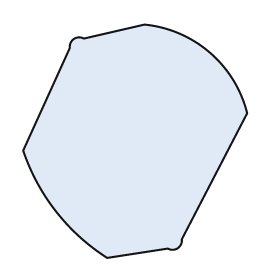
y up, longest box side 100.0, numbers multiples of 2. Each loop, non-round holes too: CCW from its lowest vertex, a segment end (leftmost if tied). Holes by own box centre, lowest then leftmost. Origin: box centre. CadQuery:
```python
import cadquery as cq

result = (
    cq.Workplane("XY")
    .moveTo(-12.0, -50.0)
    .lineTo(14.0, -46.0)
    .threePointArc((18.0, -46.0), (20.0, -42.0))
    .lineTo(48.0, 12.0)
    .threePointArc((32.0, 38.0), (4.0, 50.0))
    .lineTo(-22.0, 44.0)
    .threePointArc((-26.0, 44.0), (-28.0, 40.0))
    .lineTo(-48.0, -4.0)
    .threePointArc((-34.0, -30.0), (-12.0, -50.0))
    .close()
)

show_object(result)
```